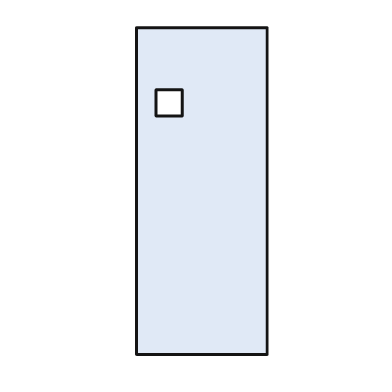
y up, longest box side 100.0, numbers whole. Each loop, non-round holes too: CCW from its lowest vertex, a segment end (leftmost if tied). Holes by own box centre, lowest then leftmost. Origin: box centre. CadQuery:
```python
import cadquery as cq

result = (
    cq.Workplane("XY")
    .moveTo(-20.0, -50.0)
    .lineTo(20.0, -50.0)
    .lineTo(20.0, 50.0)
    .lineTo(-20.0, 50.0)
    .close()
    .moveTo(-14.0, 23.0)
    .lineTo(-6.0, 23.0)
    .lineTo(-6.0, 31.0)
    .lineTo(-14.0, 31.0)
    .close()
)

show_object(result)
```